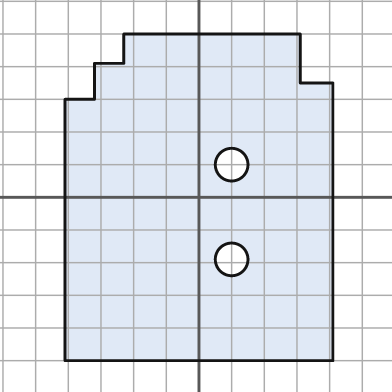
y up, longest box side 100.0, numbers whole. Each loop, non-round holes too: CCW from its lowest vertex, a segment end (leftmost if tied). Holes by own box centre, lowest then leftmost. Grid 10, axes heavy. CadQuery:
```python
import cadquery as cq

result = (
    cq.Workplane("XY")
    .moveTo(-41.0, -50.0)
    .lineTo(41.0, -50.0)
    .lineTo(41.0, 35.0)
    .lineTo(31.0, 35.0)
    .lineTo(31.0, 50.0)
    .lineTo(-23.0, 50.0)
    .lineTo(-23.0, 41.0)
    .lineTo(-32.0, 41.0)
    .lineTo(-32.0, 30.0)
    .lineTo(-41.0, 30.0)
    .close()
    .moveTo(10.0, -19.0)
    .circle(5.0)
    .moveTo(10.0, 10.0)
    .circle(5.0)
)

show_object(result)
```